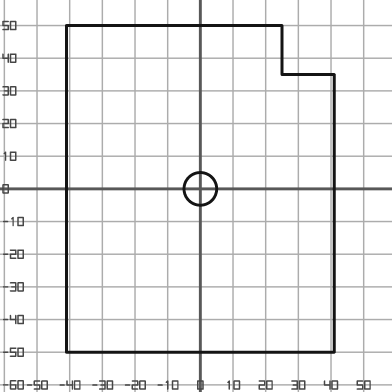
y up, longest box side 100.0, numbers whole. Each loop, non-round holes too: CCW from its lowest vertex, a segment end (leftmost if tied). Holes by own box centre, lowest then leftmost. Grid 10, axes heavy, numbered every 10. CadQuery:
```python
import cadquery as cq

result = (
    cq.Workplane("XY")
    .moveTo(-41.0, -50.0)
    .lineTo(41.0, -50.0)
    .lineTo(41.0, 35.0)
    .lineTo(25.0, 35.0)
    .lineTo(25.0, 50.0)
    .lineTo(-41.0, 50.0)
    .close()
    .moveTo(0.0, 0.0)
    .circle(5.0)
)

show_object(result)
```